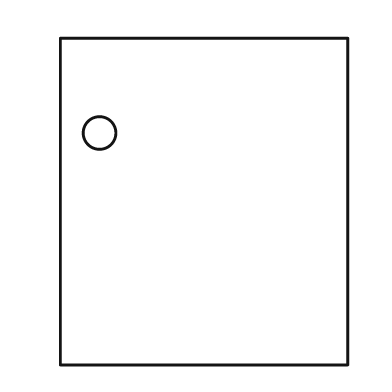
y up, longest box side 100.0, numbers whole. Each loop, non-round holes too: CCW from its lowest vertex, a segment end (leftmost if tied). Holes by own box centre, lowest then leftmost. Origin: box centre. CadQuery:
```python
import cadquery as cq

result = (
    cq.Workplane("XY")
    .moveTo(-44.0, -50.0)
    .lineTo(44.0, -50.0)
    .lineTo(44.0, 50.0)
    .lineTo(-44.0, 50.0)
    .close()
    .moveTo(-32.0, 21.0)
    .circle(5.0)
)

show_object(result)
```